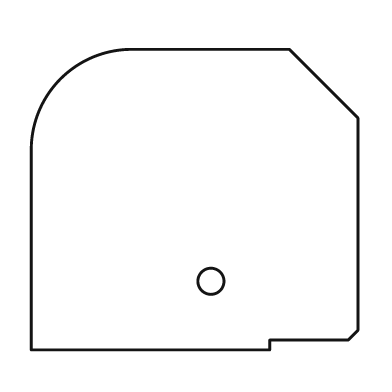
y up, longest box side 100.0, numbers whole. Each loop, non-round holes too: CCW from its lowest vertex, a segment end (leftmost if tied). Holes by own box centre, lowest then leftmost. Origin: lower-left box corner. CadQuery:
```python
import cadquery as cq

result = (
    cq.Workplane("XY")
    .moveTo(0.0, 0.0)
    .lineTo(73.0, 0.0)
    .lineTo(73.0, 3.0)
    .lineTo(97.0, 3.0)
    .lineTo(100.0, 6.0)
    .lineTo(100.0, 71.0)
    .lineTo(79.0, 92.0)
    .lineTo(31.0, 92.0)
    .threePointArc((9.0, 83.0), (0.0, 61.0))
    .close()
    .moveTo(55.0, 21.0)
    .circle(4.0)
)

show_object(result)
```